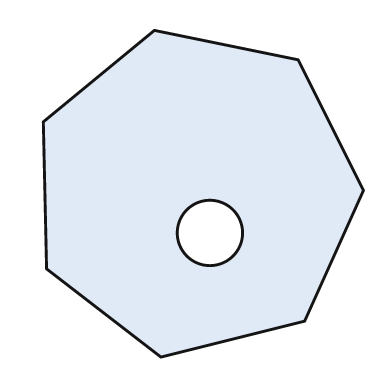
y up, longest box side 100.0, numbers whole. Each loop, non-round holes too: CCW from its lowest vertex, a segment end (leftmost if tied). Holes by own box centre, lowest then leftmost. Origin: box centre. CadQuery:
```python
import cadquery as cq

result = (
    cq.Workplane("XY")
    .moveTo(-13.0, -50.0)
    .lineTo(31.0, -39.0)
    .lineTo(49.0, 1.0)
    .lineTo(29.0, 41.0)
    .lineTo(-15.0, 50.0)
    .lineTo(-49.0, 22.0)
    .lineTo(-48.0, -23.0)
    .close()
    .moveTo(2.0, -12.0)
    .circle(10.0)
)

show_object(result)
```